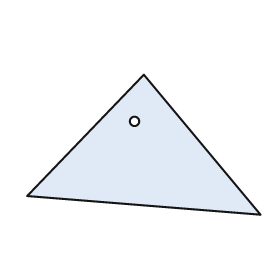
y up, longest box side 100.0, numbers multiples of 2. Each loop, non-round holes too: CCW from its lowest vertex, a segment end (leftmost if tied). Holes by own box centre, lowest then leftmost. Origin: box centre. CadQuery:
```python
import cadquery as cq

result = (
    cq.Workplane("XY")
    .moveTo(50.0, -30.0)
    .lineTo(0.0, 30.0)
    .lineTo(-50.0, -22.0)
    .close()
    .moveTo(-4.0, 10.0)
    .circle(2.0)
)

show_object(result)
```